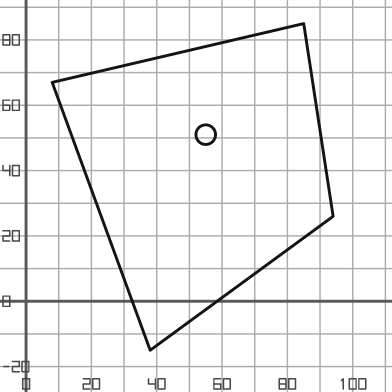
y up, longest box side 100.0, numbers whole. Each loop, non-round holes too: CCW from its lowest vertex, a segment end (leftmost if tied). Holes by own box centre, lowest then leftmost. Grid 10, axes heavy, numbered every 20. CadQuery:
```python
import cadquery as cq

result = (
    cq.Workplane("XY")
    .moveTo(38.0, -15.0)
    .lineTo(94.0, 26.0)
    .lineTo(85.0, 85.0)
    .lineTo(8.0, 67.0)
    .close()
    .moveTo(55.0, 51.0)
    .circle(3.0)
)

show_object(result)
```